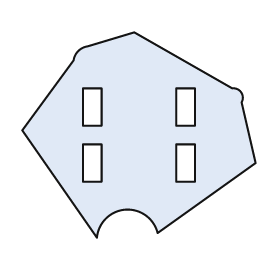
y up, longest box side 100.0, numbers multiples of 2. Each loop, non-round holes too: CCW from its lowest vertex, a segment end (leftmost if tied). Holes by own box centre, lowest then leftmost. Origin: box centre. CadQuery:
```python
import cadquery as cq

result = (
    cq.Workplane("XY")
    .moveTo(-18.0, -44.0)
    .threePointArc((-6.0, -32.0), (8.0, -42.0))
    .lineTo(50.0, -12.0)
    .lineTo(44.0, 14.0)
    .threePointArc((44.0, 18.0), (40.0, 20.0))
    .lineTo(-2.0, 44.0)
    .lineTo(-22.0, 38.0)
    .threePointArc((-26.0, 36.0), (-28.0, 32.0))
    .lineTo(-50.0, 2.0)
    .close()
    .moveTo(-24.0, -20.0)
    .lineTo(-16.0, -20.0)
    .lineTo(-16.0, -4.0)
    .lineTo(-24.0, -4.0)
    .close()
    .moveTo(16.0, -20.0)
    .lineTo(24.0, -20.0)
    .lineTo(24.0, -4.0)
    .lineTo(16.0, -4.0)
    .close()
    .moveTo(-24.0, 4.0)
    .lineTo(-16.0, 4.0)
    .lineTo(-16.0, 20.0)
    .lineTo(-24.0, 20.0)
    .close()
    .moveTo(16.0, 4.0)
    .lineTo(24.0, 4.0)
    .lineTo(24.0, 20.0)
    .lineTo(16.0, 20.0)
    .close()
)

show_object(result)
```